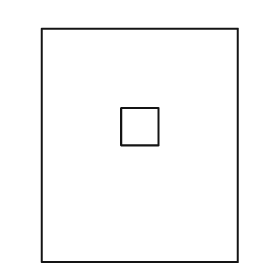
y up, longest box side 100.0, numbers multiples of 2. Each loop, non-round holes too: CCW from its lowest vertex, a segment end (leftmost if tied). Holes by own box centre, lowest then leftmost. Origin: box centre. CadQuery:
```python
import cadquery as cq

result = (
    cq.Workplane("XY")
    .moveTo(-42.0, -50.0)
    .lineTo(42.0, -50.0)
    .lineTo(42.0, 50.0)
    .lineTo(-42.0, 50.0)
    .close()
    .moveTo(-8.0, 0.0)
    .lineTo(8.0, 0.0)
    .lineTo(8.0, 16.0)
    .lineTo(-8.0, 16.0)
    .close()
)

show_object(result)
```